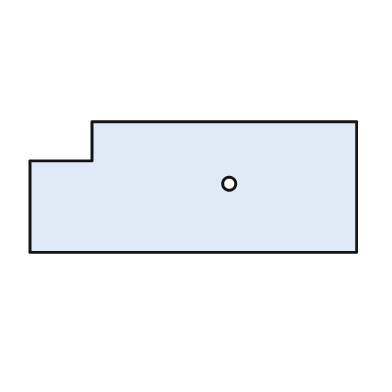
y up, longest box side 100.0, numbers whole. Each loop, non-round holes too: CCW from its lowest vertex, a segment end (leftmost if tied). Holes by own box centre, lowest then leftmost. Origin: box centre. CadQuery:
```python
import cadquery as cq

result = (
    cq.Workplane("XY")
    .moveTo(-50.0, -20.0)
    .lineTo(50.0, -20.0)
    .lineTo(50.0, 20.0)
    .lineTo(-31.0, 20.0)
    .lineTo(-31.0, 8.0)
    .lineTo(-50.0, 8.0)
    .close()
    .moveTo(11.0, 1.0)
    .circle(2.0)
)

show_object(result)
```